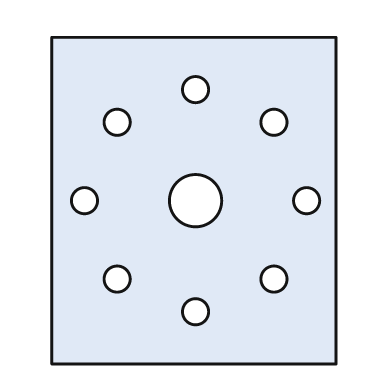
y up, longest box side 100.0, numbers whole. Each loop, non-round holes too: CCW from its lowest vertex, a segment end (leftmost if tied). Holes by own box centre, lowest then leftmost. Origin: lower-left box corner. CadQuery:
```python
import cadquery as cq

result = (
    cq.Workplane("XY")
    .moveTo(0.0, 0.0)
    .lineTo(87.0, 0.0)
    .lineTo(87.0, 100.0)
    .lineTo(0.0, 100.0)
    .close()
    .moveTo(44.0, 16.0)
    .circle(4.0)
    .moveTo(20.0, 26.0)
    .circle(4.0)
    .moveTo(68.0, 26.0)
    .circle(4.0)
    .moveTo(10.0, 50.0)
    .circle(4.0)
    .moveTo(44.0, 50.0)
    .circle(8.0)
    .moveTo(78.0, 50.0)
    .circle(4.0)
    .moveTo(20.0, 74.0)
    .circle(4.0)
    .moveTo(68.0, 74.0)
    .circle(4.0)
    .moveTo(44.0, 84.0)
    .circle(4.0)
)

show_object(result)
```